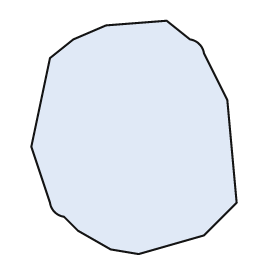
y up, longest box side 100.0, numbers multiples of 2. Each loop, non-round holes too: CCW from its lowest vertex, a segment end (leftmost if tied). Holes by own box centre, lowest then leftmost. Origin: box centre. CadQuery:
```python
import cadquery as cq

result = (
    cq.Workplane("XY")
    .moveTo(2.0, -50.0)
    .lineTo(30.0, -42.0)
    .lineTo(44.0, -28.0)
    .lineTo(40.0, 16.0)
    .lineTo(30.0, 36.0)
    .threePointArc((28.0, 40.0), (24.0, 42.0))
    .lineTo(14.0, 50.0)
    .lineTo(-12.0, 48.0)
    .lineTo(-26.0, 42.0)
    .lineTo(-36.0, 34.0)
    .lineTo(-44.0, -4.0)
    .lineTo(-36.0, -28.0)
    .threePointArc((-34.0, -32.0), (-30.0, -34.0))
    .lineTo(-24.0, -40.0)
    .lineTo(-10.0, -48.0)
    .close()
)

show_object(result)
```